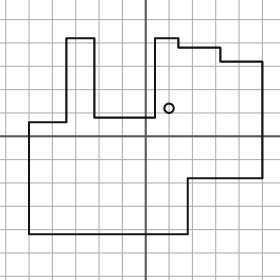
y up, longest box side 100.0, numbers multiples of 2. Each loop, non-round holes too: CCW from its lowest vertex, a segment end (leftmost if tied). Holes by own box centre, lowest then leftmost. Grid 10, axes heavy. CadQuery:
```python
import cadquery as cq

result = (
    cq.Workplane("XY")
    .moveTo(-50.0, -42.0)
    .lineTo(18.0, -42.0)
    .lineTo(18.0, -18.0)
    .lineTo(50.0, -18.0)
    .lineTo(50.0, 32.0)
    .lineTo(32.0, 32.0)
    .lineTo(32.0, 38.0)
    .lineTo(14.0, 38.0)
    .lineTo(14.0, 42.0)
    .lineTo(4.0, 42.0)
    .lineTo(4.0, 8.0)
    .lineTo(-22.0, 8.0)
    .lineTo(-22.0, 42.0)
    .lineTo(-34.0, 42.0)
    .lineTo(-34.0, 6.0)
    .lineTo(-50.0, 6.0)
    .close()
    .moveTo(10.0, 12.0)
    .circle(2.0)
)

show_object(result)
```